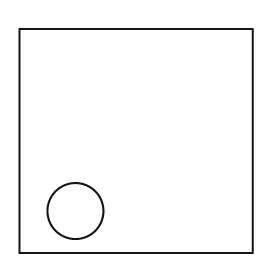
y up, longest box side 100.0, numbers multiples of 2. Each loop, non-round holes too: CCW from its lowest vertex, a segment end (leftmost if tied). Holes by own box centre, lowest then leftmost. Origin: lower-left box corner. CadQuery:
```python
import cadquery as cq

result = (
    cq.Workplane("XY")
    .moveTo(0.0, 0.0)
    .lineTo(100.0, 0.0)
    .lineTo(100.0, 96.0)
    .lineTo(0.0, 96.0)
    .close()
    .moveTo(24.0, 18.0)
    .circle(12.0)
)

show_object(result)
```